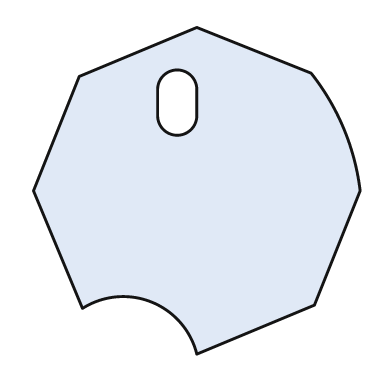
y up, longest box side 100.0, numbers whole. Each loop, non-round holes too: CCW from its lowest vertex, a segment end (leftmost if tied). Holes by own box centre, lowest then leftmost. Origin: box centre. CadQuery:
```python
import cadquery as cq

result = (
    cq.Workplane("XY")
    .moveTo(0.0, -50.0)
    .lineTo(36.0, -35.0)
    .lineTo(50.0, 0.0)
    .threePointArc((45.0, 19.0), (35.0, 36.0))
    .lineTo(0.0, 50.0)
    .lineTo(-36.0, 35.0)
    .lineTo(-50.0, 0.0)
    .lineTo(-35.0, -36.0)
    .threePointArc((-14.0, -34.0), (0.0, -50.0))
    .close()
    .moveTo(-12.0, 23.0)
    .threePointArc((-6.0, 17.0), (0.0, 23.0))
    .lineTo(0.0, 31.0)
    .threePointArc((-6.0, 37.0), (-12.0, 31.0))
    .close()
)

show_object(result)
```